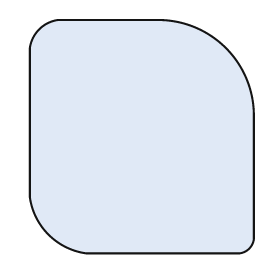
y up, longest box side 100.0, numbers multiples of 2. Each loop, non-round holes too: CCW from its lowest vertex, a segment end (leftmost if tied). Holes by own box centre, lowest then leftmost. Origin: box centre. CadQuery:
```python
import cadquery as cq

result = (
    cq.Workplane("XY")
    .moveTo(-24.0, -50.0)
    .lineTo(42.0, -50.0)
    .threePointArc((46.0, -48.0), (48.0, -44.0))
    .lineTo(48.0, 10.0)
    .threePointArc((36.0, 38.0), (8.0, 50.0))
    .lineTo(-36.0, 50.0)
    .threePointArc((-44.0, 46.0), (-48.0, 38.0))
    .lineTo(-48.0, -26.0)
    .threePointArc((-40.0, -42.0), (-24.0, -50.0))
    .close()
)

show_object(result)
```